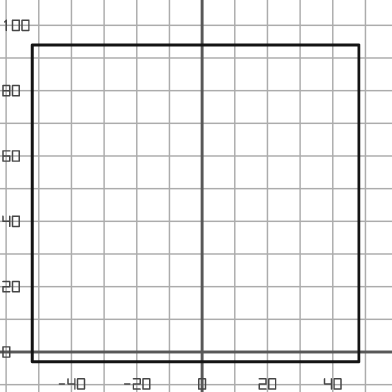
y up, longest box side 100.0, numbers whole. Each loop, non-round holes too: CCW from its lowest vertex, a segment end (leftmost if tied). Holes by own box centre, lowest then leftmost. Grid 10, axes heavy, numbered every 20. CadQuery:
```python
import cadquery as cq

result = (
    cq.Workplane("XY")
    .moveTo(-52.0, -3.0)
    .lineTo(48.0, -3.0)
    .lineTo(48.0, 94.0)
    .lineTo(-52.0, 94.0)
    .close()
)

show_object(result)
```